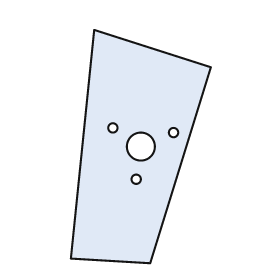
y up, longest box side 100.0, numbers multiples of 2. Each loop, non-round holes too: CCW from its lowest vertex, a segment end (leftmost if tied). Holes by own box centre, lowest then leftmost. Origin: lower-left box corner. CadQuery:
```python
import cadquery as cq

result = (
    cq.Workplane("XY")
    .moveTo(34.0, 0.0)
    .lineTo(60.0, 84.0)
    .lineTo(10.0, 100.0)
    .lineTo(0.0, 2.0)
    .close()
    .moveTo(28.0, 36.0)
    .circle(2.0)
    .moveTo(30.0, 50.0)
    .circle(6.0)
    .moveTo(44.0, 56.0)
    .circle(2.0)
    .moveTo(18.0, 58.0)
    .circle(2.0)
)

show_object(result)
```